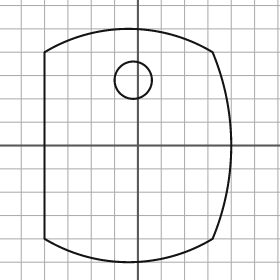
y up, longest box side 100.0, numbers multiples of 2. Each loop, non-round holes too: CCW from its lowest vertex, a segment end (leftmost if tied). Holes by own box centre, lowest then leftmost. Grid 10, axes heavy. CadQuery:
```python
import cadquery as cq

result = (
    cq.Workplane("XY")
    .moveTo(-40.0, -40.0)
    .threePointArc((-4.0, -50.0), (32.0, -40.0))
    .threePointArc((40.0, 0.0), (32.0, 40.0))
    .threePointArc((-4.0, 50.0), (-40.0, 40.0))
    .close()
    .moveTo(-2.0, 28.0)
    .circle(8.0)
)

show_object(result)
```